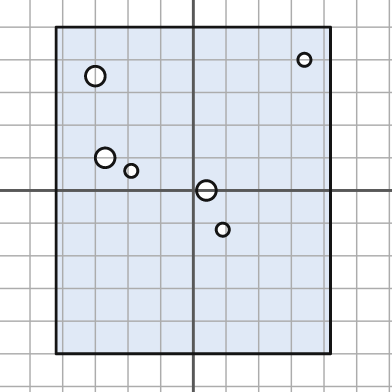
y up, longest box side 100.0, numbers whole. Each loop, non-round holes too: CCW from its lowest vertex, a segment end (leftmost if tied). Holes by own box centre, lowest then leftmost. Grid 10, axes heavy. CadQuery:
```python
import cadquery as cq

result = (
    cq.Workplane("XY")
    .moveTo(-42.0, -50.0)
    .lineTo(42.0, -50.0)
    .lineTo(42.0, 50.0)
    .lineTo(-42.0, 50.0)
    .close()
    .moveTo(9.0, -12.0)
    .circle(2.0)
    .moveTo(4.0, 0.0)
    .circle(3.0)
    .moveTo(-19.0, 6.0)
    .circle(2.0)
    .moveTo(-27.0, 10.0)
    .circle(3.0)
    .moveTo(-30.0, 35.0)
    .circle(3.0)
    .moveTo(34.0, 40.0)
    .circle(2.0)
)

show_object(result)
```